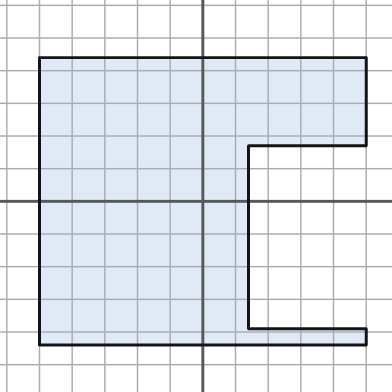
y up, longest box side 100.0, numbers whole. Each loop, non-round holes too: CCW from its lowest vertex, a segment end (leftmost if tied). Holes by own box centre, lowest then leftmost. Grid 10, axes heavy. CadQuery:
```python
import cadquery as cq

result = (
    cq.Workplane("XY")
    .moveTo(-50.0, -44.0)
    .lineTo(50.0, -44.0)
    .lineTo(50.0, -39.0)
    .lineTo(14.0, -39.0)
    .lineTo(14.0, 17.0)
    .lineTo(50.0, 17.0)
    .lineTo(50.0, 44.0)
    .lineTo(-50.0, 44.0)
    .close()
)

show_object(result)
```